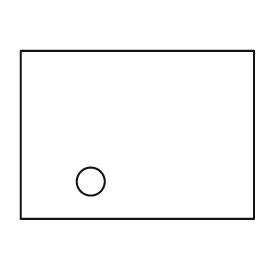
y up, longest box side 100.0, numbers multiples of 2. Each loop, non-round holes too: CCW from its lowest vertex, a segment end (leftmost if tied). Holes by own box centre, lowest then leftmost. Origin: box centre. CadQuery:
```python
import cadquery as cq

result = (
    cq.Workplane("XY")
    .moveTo(-50.0, -36.0)
    .lineTo(50.0, -36.0)
    .lineTo(50.0, 36.0)
    .lineTo(-50.0, 36.0)
    .close()
    .moveTo(-20.0, -20.0)
    .circle(6.0)
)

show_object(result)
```